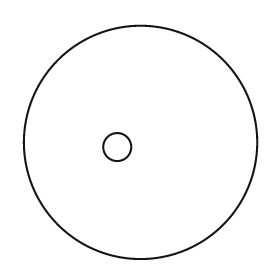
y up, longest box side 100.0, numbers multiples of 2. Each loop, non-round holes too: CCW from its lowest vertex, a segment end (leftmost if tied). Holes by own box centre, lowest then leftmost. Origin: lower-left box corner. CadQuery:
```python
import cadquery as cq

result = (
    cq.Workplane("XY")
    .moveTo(50.0, 50.0)
    .circle(50.0)
    .moveTo(40.0, 48.0)
    .circle(6.0)
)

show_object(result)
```